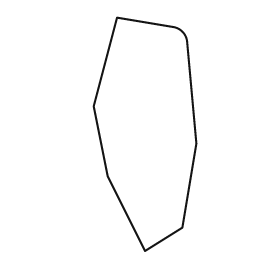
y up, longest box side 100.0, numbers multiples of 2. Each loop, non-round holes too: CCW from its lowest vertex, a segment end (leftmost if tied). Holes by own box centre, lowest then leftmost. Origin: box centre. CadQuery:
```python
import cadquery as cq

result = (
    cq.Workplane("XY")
    .moveTo(0.0, -50.0)
    .lineTo(16.0, -40.0)
    .lineTo(22.0, -4.0)
    .lineTo(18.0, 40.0)
    .threePointArc((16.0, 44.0), (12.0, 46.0))
    .lineTo(-12.0, 50.0)
    .lineTo(-22.0, 12.0)
    .lineTo(-16.0, -18.0)
    .close()
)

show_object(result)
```